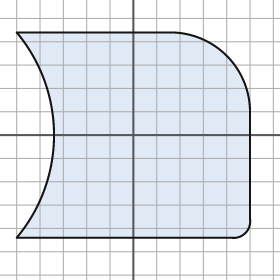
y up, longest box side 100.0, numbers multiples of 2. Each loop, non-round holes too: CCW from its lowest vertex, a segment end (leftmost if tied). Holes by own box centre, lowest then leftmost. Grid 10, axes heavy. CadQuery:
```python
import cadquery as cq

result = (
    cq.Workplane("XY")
    .moveTo(-50.0, -44.0)
    .lineTo(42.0, -44.0)
    .threePointArc((48.0, -42.0), (50.0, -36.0))
    .lineTo(50.0, 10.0)
    .threePointArc((40.0, 34.0), (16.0, 44.0))
    .lineTo(-50.0, 44.0)
    .threePointArc((-34.0, 0.0), (-50.0, -44.0))
    .close()
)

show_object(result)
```